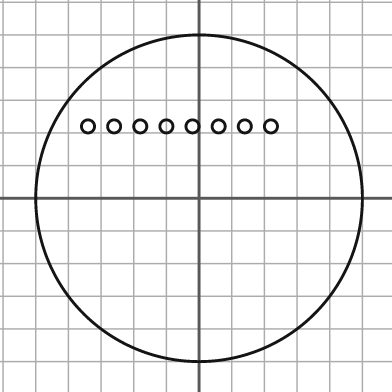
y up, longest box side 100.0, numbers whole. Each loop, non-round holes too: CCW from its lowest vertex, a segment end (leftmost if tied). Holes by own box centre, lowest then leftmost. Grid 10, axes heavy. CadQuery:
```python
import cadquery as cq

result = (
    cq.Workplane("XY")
    .moveTo(0.0, 0.0)
    .circle(50.0)
    .moveTo(-34.0, 22.0)
    .circle(2.0)
    .moveTo(-26.0, 22.0)
    .circle(2.0)
    .moveTo(-18.0, 22.0)
    .circle(2.0)
    .moveTo(-10.0, 22.0)
    .circle(2.0)
    .moveTo(-2.0, 22.0)
    .circle(2.0)
    .moveTo(6.0, 22.0)
    .circle(2.0)
    .moveTo(14.0, 22.0)
    .circle(2.0)
    .moveTo(22.0, 22.0)
    .circle(2.0)
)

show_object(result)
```